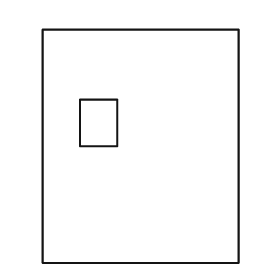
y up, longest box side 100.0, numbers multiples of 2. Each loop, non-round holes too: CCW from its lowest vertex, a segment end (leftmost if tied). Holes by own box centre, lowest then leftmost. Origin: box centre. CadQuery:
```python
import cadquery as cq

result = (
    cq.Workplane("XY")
    .moveTo(-42.0, -50.0)
    .lineTo(42.0, -50.0)
    .lineTo(42.0, 50.0)
    .lineTo(-42.0, 50.0)
    .close()
    .moveTo(-26.0, 0.0)
    .lineTo(-10.0, 0.0)
    .lineTo(-10.0, 20.0)
    .lineTo(-26.0, 20.0)
    .close()
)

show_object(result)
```